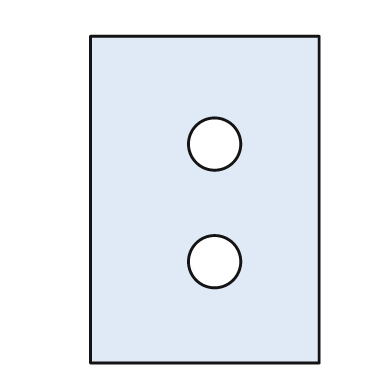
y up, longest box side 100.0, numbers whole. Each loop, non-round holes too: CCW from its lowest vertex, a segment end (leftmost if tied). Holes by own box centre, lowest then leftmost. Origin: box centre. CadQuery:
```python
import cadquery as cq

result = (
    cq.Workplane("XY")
    .moveTo(-35.0, -50.0)
    .lineTo(35.0, -50.0)
    .lineTo(35.0, 50.0)
    .lineTo(-35.0, 50.0)
    .close()
    .moveTo(3.0, -19.0)
    .circle(8.0)
    .moveTo(3.0, 17.0)
    .circle(8.0)
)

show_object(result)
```